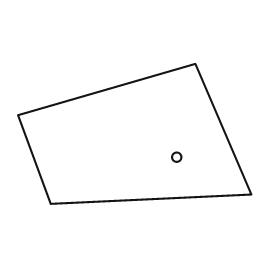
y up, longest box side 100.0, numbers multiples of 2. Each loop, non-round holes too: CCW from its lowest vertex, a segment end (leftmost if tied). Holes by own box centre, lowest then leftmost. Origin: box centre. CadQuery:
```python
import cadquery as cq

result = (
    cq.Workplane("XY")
    .moveTo(-36.0, -30.0)
    .lineTo(50.0, -26.0)
    .lineTo(26.0, 30.0)
    .lineTo(-50.0, 8.0)
    .close()
    .moveTo(18.0, -10.0)
    .circle(2.0)
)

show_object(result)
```